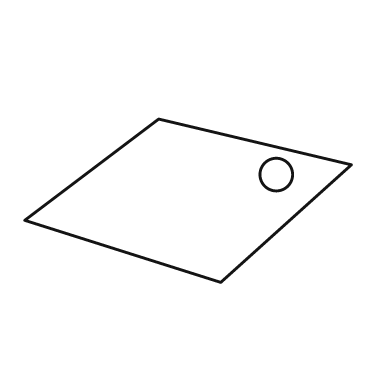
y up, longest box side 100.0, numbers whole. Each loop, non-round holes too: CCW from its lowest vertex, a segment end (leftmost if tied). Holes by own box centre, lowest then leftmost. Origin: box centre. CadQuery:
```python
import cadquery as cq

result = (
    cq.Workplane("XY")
    .moveTo(10.0, -25.0)
    .lineTo(50.0, 11.0)
    .lineTo(-9.0, 25.0)
    .lineTo(-50.0, -6.0)
    .close()
    .moveTo(27.0, 8.0)
    .circle(5.0)
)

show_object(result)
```